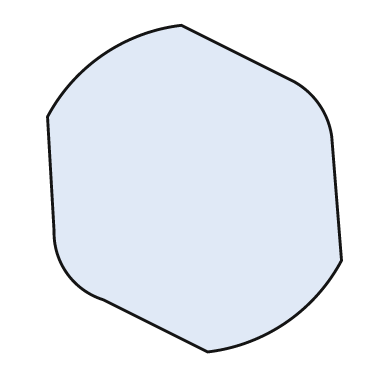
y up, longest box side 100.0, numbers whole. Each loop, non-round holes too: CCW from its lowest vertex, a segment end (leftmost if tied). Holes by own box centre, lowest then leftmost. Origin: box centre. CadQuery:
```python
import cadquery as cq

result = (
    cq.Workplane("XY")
    .moveTo(4.0, -50.0)
    .threePointArc((28.0, -41.0), (45.0, -22.0))
    .lineTo(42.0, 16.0)
    .threePointArc((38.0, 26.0), (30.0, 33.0))
    .lineTo(-4.0, 50.0)
    .threePointArc((-28.0, 41.0), (-45.0, 22.0))
    .lineTo(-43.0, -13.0)
    .threePointArc((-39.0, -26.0), (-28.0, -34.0))
    .close()
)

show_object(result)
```